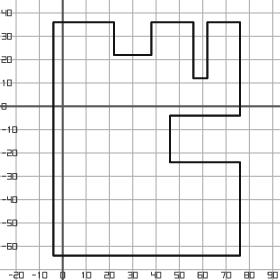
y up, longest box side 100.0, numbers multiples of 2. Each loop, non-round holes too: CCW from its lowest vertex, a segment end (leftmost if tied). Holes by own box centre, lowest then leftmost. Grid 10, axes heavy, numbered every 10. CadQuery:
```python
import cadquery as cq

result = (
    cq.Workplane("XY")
    .moveTo(-4.0, -64.0)
    .lineTo(76.0, -64.0)
    .lineTo(76.0, -24.0)
    .lineTo(46.0, -24.0)
    .lineTo(46.0, -4.0)
    .lineTo(76.0, -4.0)
    .lineTo(76.0, 36.0)
    .lineTo(62.0, 36.0)
    .lineTo(62.0, 12.0)
    .lineTo(56.0, 12.0)
    .lineTo(56.0, 36.0)
    .lineTo(38.0, 36.0)
    .lineTo(38.0, 22.0)
    .lineTo(22.0, 22.0)
    .lineTo(22.0, 36.0)
    .lineTo(-4.0, 36.0)
    .close()
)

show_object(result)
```